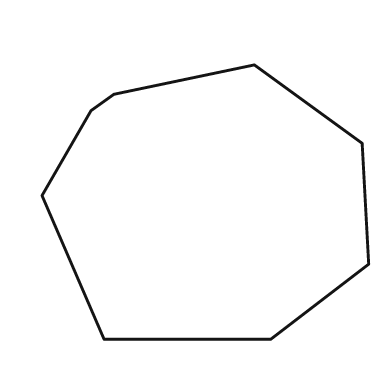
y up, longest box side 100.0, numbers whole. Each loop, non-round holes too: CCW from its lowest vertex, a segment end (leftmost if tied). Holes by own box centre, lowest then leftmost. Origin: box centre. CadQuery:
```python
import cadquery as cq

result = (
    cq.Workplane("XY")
    .moveTo(-31.0, -42.0)
    .lineTo(20.0, -42.0)
    .lineTo(50.0, -19.0)
    .lineTo(48.0, 18.0)
    .lineTo(15.0, 42.0)
    .lineTo(-28.0, 33.0)
    .lineTo(-35.0, 28.0)
    .lineTo(-50.0, 2.0)
    .close()
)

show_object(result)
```